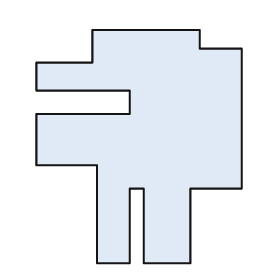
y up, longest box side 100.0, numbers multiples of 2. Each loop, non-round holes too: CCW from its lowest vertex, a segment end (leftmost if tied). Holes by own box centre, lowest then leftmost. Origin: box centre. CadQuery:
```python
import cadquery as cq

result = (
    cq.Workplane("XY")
    .moveTo(-18.0, -50.0)
    .lineTo(-4.0, -50.0)
    .lineTo(-4.0, -18.0)
    .lineTo(2.0, -18.0)
    .lineTo(2.0, -50.0)
    .lineTo(22.0, -50.0)
    .lineTo(22.0, -18.0)
    .lineTo(44.0, -18.0)
    .lineTo(44.0, 42.0)
    .lineTo(26.0, 42.0)
    .lineTo(26.0, 50.0)
    .lineTo(-20.0, 50.0)
    .lineTo(-20.0, 36.0)
    .lineTo(-44.0, 36.0)
    .lineTo(-44.0, 24.0)
    .lineTo(-4.0, 24.0)
    .lineTo(-4.0, 14.0)
    .lineTo(-44.0, 14.0)
    .lineTo(-44.0, -8.0)
    .lineTo(-18.0, -8.0)
    .close()
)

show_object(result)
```